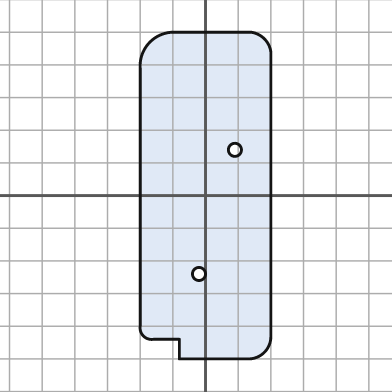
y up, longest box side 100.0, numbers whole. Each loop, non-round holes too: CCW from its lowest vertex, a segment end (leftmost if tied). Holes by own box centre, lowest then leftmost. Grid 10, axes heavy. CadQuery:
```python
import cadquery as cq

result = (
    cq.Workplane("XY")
    .moveTo(-8.0, -50.0)
    .lineTo(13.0, -50.0)
    .threePointArc((18.0, -48.0), (20.0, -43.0))
    .lineTo(20.0, 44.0)
    .threePointArc((18.0, 48.0), (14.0, 50.0))
    .lineTo(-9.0, 50.0)
    .threePointArc((-17.0, 47.0), (-20.0, 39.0))
    .lineTo(-20.0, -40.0)
    .threePointArc((-19.0, -43.0), (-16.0, -44.0))
    .lineTo(-8.0, -44.0)
    .close()
    .moveTo(-2.0, -24.0)
    .circle(2.0)
    .moveTo(9.0, 14.0)
    .circle(2.0)
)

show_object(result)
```